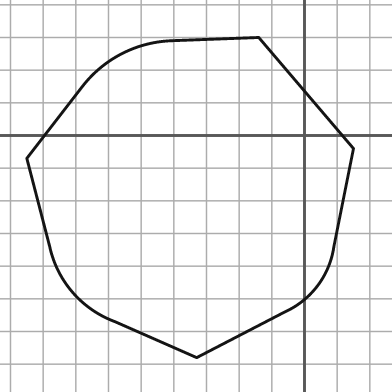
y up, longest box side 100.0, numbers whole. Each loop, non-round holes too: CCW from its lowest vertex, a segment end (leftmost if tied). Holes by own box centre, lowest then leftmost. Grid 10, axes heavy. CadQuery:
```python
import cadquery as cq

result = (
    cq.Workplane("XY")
    .moveTo(-33.0, -68.0)
    .lineTo(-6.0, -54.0)
    .threePointArc((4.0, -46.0), (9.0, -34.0))
    .lineTo(15.0, -4.0)
    .lineTo(-14.0, 30.0)
    .lineTo(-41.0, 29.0)
    .threePointArc((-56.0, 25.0), (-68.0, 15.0))
    .lineTo(-85.0, -7.0)
    .lineTo(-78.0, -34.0)
    .threePointArc((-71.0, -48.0), (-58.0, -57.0))
    .close()
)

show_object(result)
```